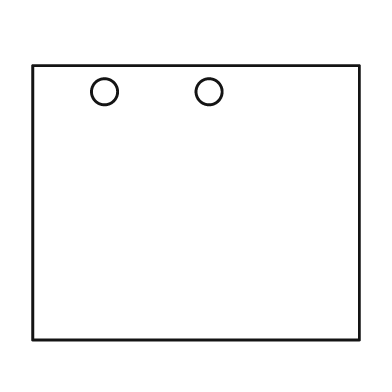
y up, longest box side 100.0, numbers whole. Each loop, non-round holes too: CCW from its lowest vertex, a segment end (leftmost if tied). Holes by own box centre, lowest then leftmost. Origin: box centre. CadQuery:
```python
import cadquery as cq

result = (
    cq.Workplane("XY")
    .moveTo(-50.0, -42.0)
    .lineTo(50.0, -42.0)
    .lineTo(50.0, 42.0)
    .lineTo(-50.0, 42.0)
    .close()
    .moveTo(-28.0, 34.0)
    .circle(4.0)
    .moveTo(4.0, 34.0)
    .circle(4.0)
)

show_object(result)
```